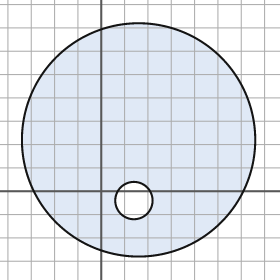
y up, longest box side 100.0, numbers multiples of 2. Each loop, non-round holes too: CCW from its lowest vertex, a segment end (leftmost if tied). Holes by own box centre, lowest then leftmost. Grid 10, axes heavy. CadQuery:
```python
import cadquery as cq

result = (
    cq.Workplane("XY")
    .moveTo(16.0, 22.0)
    .circle(50.0)
    .moveTo(14.0, -4.0)
    .circle(8.0)
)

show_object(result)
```